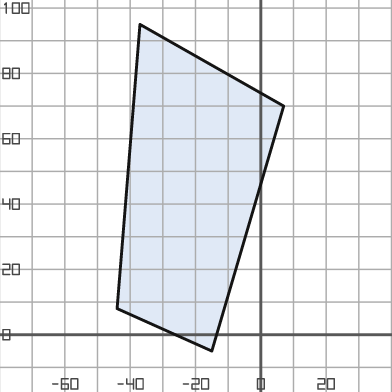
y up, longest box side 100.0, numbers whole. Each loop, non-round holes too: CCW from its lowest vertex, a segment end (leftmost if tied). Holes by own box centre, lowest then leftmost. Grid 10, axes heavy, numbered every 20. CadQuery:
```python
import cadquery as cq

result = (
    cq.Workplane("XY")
    .moveTo(-15.0, -5.0)
    .lineTo(7.0, 70.0)
    .lineTo(-37.0, 95.0)
    .lineTo(-44.0, 8.0)
    .close()
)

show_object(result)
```